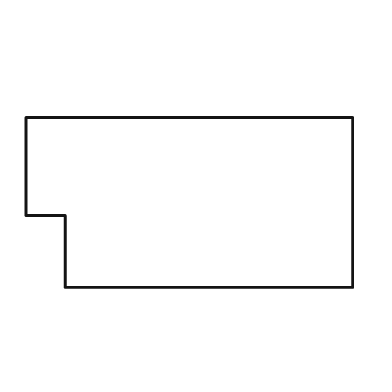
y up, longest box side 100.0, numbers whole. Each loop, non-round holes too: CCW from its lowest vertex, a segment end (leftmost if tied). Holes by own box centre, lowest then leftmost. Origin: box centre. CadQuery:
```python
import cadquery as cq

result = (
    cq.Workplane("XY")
    .moveTo(-38.0, -26.0)
    .lineTo(50.0, -26.0)
    .lineTo(50.0, 26.0)
    .lineTo(-50.0, 26.0)
    .lineTo(-50.0, -4.0)
    .lineTo(-38.0, -4.0)
    .close()
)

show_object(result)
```